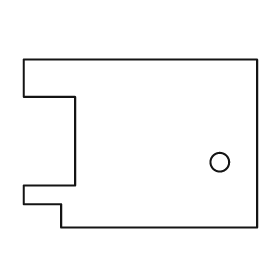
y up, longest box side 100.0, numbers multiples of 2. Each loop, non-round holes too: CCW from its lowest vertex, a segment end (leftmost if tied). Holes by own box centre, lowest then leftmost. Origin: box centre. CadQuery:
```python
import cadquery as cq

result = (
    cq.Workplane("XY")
    .moveTo(-34.0, -36.0)
    .lineTo(50.0, -36.0)
    .lineTo(50.0, 36.0)
    .lineTo(-50.0, 36.0)
    .lineTo(-50.0, 20.0)
    .lineTo(-28.0, 20.0)
    .lineTo(-28.0, -18.0)
    .lineTo(-50.0, -18.0)
    .lineTo(-50.0, -26.0)
    .lineTo(-34.0, -26.0)
    .close()
    .moveTo(34.0, -8.0)
    .circle(4.0)
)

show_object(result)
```